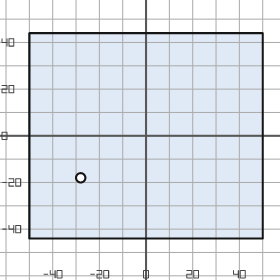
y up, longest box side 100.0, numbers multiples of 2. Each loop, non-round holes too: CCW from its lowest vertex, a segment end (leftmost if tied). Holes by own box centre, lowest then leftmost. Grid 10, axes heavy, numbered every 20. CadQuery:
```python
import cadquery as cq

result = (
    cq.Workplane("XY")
    .moveTo(-50.0, -44.0)
    .lineTo(50.0, -44.0)
    .lineTo(50.0, 44.0)
    .lineTo(-50.0, 44.0)
    .close()
    .moveTo(-28.0, -18.0)
    .circle(2.0)
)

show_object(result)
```